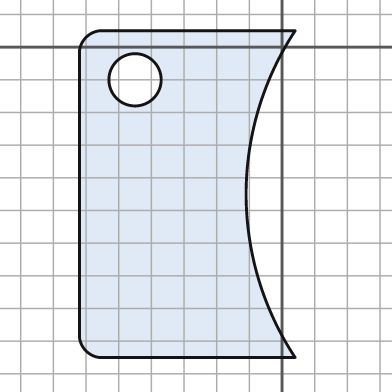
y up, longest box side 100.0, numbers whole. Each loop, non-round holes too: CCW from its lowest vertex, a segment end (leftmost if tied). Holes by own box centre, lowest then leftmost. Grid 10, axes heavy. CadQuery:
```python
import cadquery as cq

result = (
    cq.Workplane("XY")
    .moveTo(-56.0, -95.0)
    .lineTo(4.0, -95.0)
    .threePointArc((-11.0, -45.0), (4.0, 5.0))
    .lineTo(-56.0, 5.0)
    .threePointArc((-60.0, 3.0), (-62.0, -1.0))
    .lineTo(-62.0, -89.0)
    .threePointArc((-60.0, -93.0), (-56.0, -95.0))
    .close()
    .moveTo(-45.0, -10.0)
    .circle(8.0)
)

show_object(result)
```